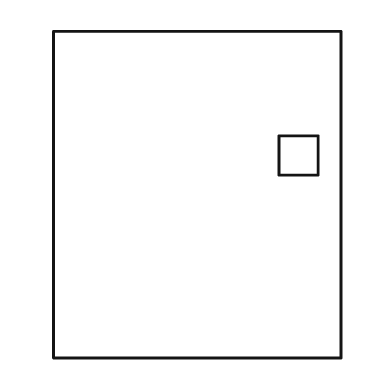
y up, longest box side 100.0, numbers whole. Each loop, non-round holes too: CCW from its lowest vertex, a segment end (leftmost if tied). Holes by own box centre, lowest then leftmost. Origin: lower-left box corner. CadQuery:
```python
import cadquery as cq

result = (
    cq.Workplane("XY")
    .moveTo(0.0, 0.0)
    .lineTo(88.0, 0.0)
    .lineTo(88.0, 100.0)
    .lineTo(0.0, 100.0)
    .close()
    .moveTo(69.0, 56.0)
    .lineTo(81.0, 56.0)
    .lineTo(81.0, 68.0)
    .lineTo(69.0, 68.0)
    .close()
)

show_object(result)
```